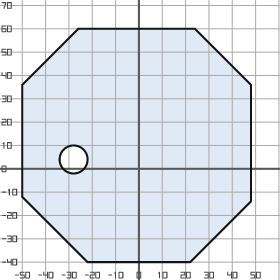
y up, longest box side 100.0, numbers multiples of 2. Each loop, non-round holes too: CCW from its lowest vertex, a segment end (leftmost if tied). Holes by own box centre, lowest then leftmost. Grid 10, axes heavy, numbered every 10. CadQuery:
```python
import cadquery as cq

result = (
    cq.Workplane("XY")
    .moveTo(-22.0, -40.0)
    .lineTo(22.0, -40.0)
    .lineTo(48.0, -14.0)
    .lineTo(48.0, 36.0)
    .lineTo(24.0, 60.0)
    .lineTo(-26.0, 60.0)
    .lineTo(-50.0, 36.0)
    .lineTo(-50.0, -12.0)
    .close()
    .moveTo(-28.0, 4.0)
    .circle(6.0)
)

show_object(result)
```